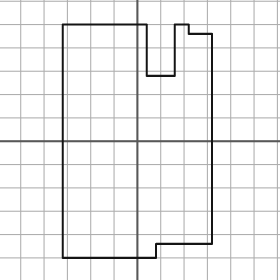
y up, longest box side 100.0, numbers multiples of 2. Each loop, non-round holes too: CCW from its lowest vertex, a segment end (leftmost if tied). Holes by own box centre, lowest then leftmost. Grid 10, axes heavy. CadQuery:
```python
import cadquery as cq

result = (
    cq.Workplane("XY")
    .moveTo(-32.0, -50.0)
    .lineTo(8.0, -50.0)
    .lineTo(8.0, -44.0)
    .lineTo(32.0, -44.0)
    .lineTo(32.0, 46.0)
    .lineTo(22.0, 46.0)
    .lineTo(22.0, 50.0)
    .lineTo(16.0, 50.0)
    .lineTo(16.0, 28.0)
    .lineTo(4.0, 28.0)
    .lineTo(4.0, 50.0)
    .lineTo(-32.0, 50.0)
    .close()
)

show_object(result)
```